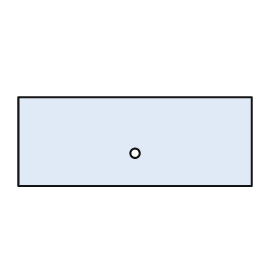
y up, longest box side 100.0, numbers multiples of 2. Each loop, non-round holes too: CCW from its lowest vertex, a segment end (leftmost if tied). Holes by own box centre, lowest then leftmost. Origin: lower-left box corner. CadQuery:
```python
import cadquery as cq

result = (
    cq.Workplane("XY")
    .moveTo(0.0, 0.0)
    .lineTo(100.0, 0.0)
    .lineTo(100.0, 38.0)
    .lineTo(0.0, 38.0)
    .close()
    .moveTo(50.0, 14.0)
    .circle(2.0)
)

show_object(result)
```